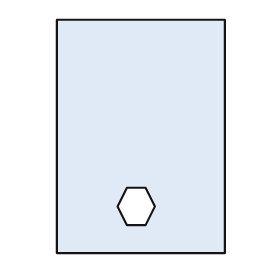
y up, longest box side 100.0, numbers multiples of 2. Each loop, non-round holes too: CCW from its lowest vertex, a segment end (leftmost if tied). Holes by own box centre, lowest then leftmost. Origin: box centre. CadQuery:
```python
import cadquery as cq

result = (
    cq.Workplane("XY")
    .moveTo(-36.0, -50.0)
    .lineTo(36.0, -50.0)
    .lineTo(36.0, 50.0)
    .lineTo(-36.0, 50.0)
    .close()
    .moveTo(-6.0, -38.0)
    .lineTo(2.0, -38.0)
    .lineTo(6.0, -30.0)
    .lineTo(2.0, -22.0)
    .lineTo(-6.0, -22.0)
    .lineTo(-10.0, -30.0)
    .close()
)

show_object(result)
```